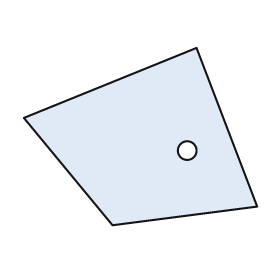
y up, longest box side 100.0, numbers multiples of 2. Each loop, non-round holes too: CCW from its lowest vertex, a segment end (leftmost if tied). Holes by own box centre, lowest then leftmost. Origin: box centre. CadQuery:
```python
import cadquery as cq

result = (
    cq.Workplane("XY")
    .moveTo(-12.0, -38.0)
    .lineTo(50.0, -30.0)
    .lineTo(24.0, 38.0)
    .lineTo(-50.0, 8.0)
    .close()
    .moveTo(20.0, -6.0)
    .circle(4.0)
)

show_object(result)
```